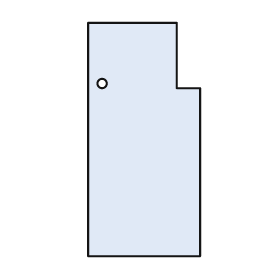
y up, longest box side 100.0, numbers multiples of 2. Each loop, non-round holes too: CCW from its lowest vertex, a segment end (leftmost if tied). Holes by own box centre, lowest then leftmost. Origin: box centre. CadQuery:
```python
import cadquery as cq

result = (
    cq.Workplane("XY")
    .moveTo(-24.0, -50.0)
    .lineTo(24.0, -50.0)
    .lineTo(24.0, 22.0)
    .lineTo(14.0, 22.0)
    .lineTo(14.0, 50.0)
    .lineTo(-24.0, 50.0)
    .close()
    .moveTo(-18.0, 24.0)
    .circle(2.0)
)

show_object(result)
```